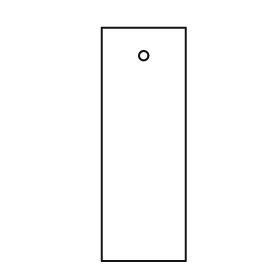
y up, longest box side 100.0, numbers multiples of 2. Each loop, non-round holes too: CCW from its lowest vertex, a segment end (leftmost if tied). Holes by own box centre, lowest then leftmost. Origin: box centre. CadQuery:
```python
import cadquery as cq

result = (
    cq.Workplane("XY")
    .moveTo(-18.0, -50.0)
    .lineTo(18.0, -50.0)
    .lineTo(18.0, 50.0)
    .lineTo(-18.0, 50.0)
    .close()
    .moveTo(0.0, 38.0)
    .circle(2.0)
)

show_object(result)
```